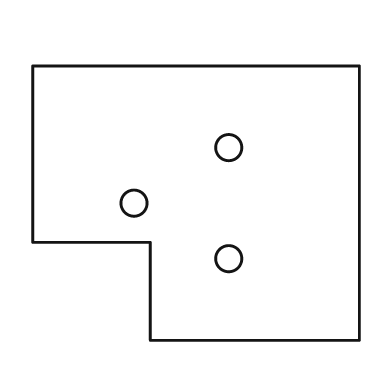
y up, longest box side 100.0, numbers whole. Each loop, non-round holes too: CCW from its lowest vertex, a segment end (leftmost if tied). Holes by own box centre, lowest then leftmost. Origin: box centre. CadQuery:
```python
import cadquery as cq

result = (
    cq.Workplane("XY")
    .moveTo(-14.0, -42.0)
    .lineTo(50.0, -42.0)
    .lineTo(50.0, 42.0)
    .lineTo(-50.0, 42.0)
    .lineTo(-50.0, -12.0)
    .lineTo(-14.0, -12.0)
    .close()
    .moveTo(10.0, -17.0)
    .circle(4.0)
    .moveTo(-19.0, 0.0)
    .circle(4.0)
    .moveTo(10.0, 17.0)
    .circle(4.0)
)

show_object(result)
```